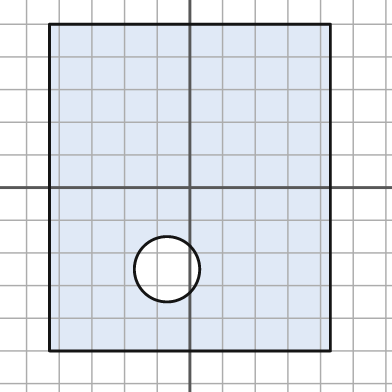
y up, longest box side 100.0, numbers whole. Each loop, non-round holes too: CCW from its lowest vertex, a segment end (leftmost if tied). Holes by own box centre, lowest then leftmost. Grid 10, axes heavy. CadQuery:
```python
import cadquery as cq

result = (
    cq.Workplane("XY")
    .moveTo(-43.0, -50.0)
    .lineTo(43.0, -50.0)
    .lineTo(43.0, 50.0)
    .lineTo(-43.0, 50.0)
    .close()
    .moveTo(-7.0, -25.0)
    .circle(10.0)
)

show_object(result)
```